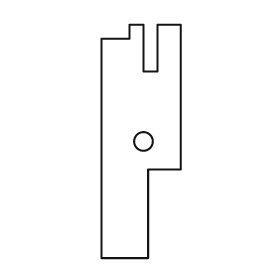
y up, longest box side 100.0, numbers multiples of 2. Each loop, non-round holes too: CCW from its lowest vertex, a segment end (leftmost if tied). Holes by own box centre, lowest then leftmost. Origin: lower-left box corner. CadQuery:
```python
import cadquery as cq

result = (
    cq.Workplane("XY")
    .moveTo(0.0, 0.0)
    .lineTo(20.0, 0.0)
    .lineTo(20.0, 38.0)
    .lineTo(34.0, 38.0)
    .lineTo(34.0, 100.0)
    .lineTo(24.0, 100.0)
    .lineTo(24.0, 80.0)
    .lineTo(18.0, 80.0)
    .lineTo(18.0, 100.0)
    .lineTo(12.0, 100.0)
    .lineTo(12.0, 94.0)
    .lineTo(0.0, 94.0)
    .close()
    .moveTo(18.0, 50.0)
    .circle(4.0)
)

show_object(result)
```